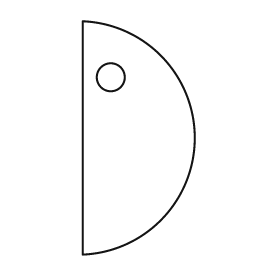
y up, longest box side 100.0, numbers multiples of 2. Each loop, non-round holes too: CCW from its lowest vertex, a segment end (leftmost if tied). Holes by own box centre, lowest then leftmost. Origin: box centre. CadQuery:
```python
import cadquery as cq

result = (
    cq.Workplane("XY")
    .moveTo(-24.0, -50.0)
    .threePointArc((24.0, 0.0), (-24.0, 50.0))
    .close()
    .moveTo(-12.0, 26.0)
    .circle(6.0)
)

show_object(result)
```